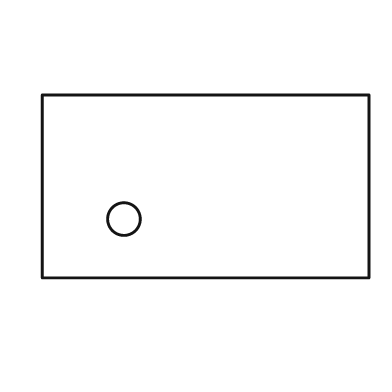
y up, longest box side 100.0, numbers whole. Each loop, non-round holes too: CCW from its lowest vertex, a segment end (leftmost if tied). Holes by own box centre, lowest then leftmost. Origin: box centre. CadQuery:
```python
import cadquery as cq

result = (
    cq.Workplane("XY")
    .moveTo(-50.0, -28.0)
    .lineTo(50.0, -28.0)
    .lineTo(50.0, 28.0)
    .lineTo(-50.0, 28.0)
    .close()
    .moveTo(-25.0, -10.0)
    .circle(5.0)
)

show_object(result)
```